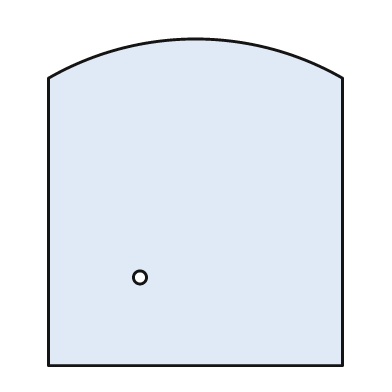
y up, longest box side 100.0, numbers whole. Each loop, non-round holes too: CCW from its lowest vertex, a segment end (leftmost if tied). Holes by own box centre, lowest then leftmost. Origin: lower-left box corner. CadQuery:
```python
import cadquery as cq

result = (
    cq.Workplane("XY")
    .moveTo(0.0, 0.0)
    .lineTo(90.0, 0.0)
    .lineTo(90.0, 88.0)
    .threePointArc((45.0, 100.0), (0.0, 88.0))
    .close()
    .moveTo(28.0, 27.0)
    .circle(2.0)
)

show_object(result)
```